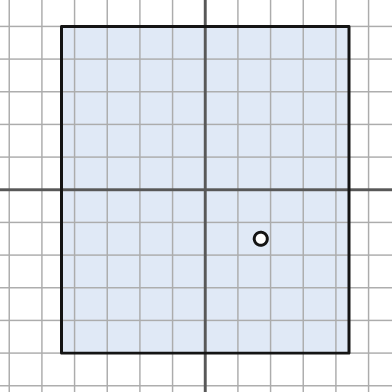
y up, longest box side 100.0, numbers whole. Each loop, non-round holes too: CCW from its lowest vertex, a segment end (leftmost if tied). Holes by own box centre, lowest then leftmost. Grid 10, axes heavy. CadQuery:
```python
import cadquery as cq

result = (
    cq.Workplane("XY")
    .moveTo(-44.0, -50.0)
    .lineTo(44.0, -50.0)
    .lineTo(44.0, 50.0)
    .lineTo(-44.0, 50.0)
    .close()
    .moveTo(17.0, -15.0)
    .circle(2.0)
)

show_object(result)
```